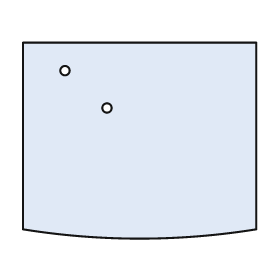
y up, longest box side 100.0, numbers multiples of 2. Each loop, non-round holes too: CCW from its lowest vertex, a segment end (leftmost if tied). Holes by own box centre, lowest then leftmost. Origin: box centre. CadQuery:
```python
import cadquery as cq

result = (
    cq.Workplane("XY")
    .moveTo(-50.0, -38.0)
    .threePointArc((0.0, -42.0), (50.0, -38.0))
    .lineTo(50.0, 42.0)
    .lineTo(-50.0, 42.0)
    .close()
    .moveTo(-14.0, 14.0)
    .circle(2.0)
    .moveTo(-32.0, 30.0)
    .circle(2.0)
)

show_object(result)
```